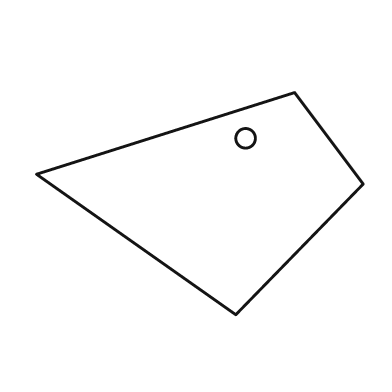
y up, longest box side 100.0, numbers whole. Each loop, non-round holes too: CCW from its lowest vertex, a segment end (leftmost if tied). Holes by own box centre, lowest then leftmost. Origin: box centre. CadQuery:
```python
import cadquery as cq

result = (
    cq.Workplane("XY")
    .moveTo(11.0, -34.0)
    .lineTo(50.0, 6.0)
    .lineTo(29.0, 34.0)
    .lineTo(-50.0, 9.0)
    .close()
    .moveTo(14.0, 20.0)
    .circle(3.0)
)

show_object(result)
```